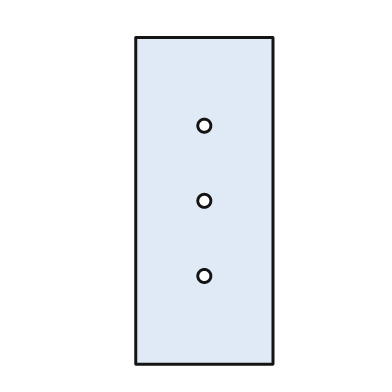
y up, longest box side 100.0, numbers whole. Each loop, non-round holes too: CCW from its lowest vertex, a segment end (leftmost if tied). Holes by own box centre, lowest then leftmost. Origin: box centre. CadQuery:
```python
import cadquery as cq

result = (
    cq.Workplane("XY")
    .moveTo(-21.0, -50.0)
    .lineTo(21.0, -50.0)
    .lineTo(21.0, 50.0)
    .lineTo(-21.0, 50.0)
    .close()
    .moveTo(0.0, -23.0)
    .circle(2.0)
    .moveTo(0.0, 0.0)
    .circle(2.0)
    .moveTo(0.0, 23.0)
    .circle(2.0)
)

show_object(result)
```